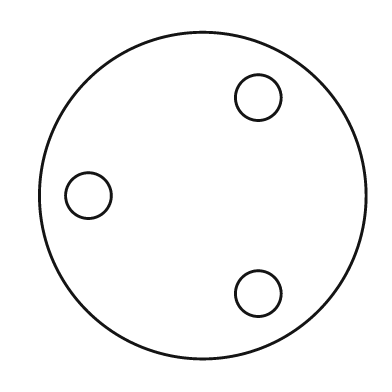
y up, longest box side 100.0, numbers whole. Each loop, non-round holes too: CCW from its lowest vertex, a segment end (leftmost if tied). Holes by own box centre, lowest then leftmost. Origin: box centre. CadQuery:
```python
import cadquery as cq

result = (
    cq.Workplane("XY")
    .moveTo(0.0, 0.0)
    .circle(50.0)
    .moveTo(17.0, -30.0)
    .circle(7.0)
    .moveTo(-35.0, 0.0)
    .circle(7.0)
    .moveTo(17.0, 30.0)
    .circle(7.0)
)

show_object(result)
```